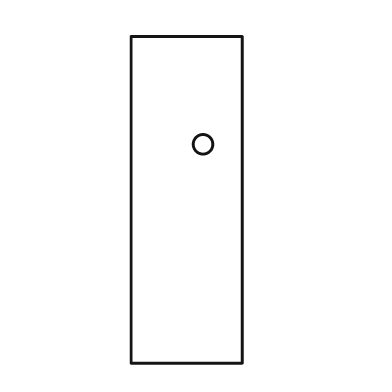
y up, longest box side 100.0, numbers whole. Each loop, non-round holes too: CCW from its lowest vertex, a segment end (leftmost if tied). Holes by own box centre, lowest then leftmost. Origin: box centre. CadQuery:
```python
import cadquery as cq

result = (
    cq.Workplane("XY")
    .moveTo(-17.0, -50.0)
    .lineTo(17.0, -50.0)
    .lineTo(17.0, 50.0)
    .lineTo(-17.0, 50.0)
    .close()
    .moveTo(5.0, 17.0)
    .circle(3.0)
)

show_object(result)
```